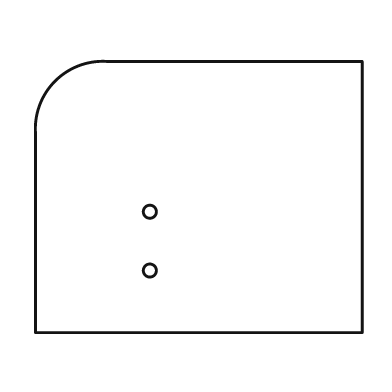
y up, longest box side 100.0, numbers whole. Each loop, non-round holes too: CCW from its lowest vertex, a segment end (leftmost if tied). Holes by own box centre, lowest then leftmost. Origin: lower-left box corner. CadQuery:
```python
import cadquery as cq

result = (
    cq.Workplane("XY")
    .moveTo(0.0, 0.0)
    .lineTo(100.0, 0.0)
    .lineTo(100.0, 83.0)
    .lineTo(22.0, 83.0)
    .threePointArc((6.0, 77.0), (0.0, 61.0))
    .close()
    .moveTo(35.0, 19.0)
    .circle(2.0)
    .moveTo(35.0, 37.0)
    .circle(2.0)
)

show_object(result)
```